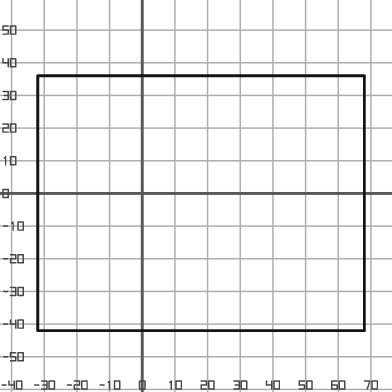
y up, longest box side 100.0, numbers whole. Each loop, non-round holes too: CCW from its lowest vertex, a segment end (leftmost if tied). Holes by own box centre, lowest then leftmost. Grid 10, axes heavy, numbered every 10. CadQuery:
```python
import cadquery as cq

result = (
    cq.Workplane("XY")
    .moveTo(-32.0, -42.0)
    .lineTo(68.0, -42.0)
    .lineTo(68.0, 36.0)
    .lineTo(-32.0, 36.0)
    .close()
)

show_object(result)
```